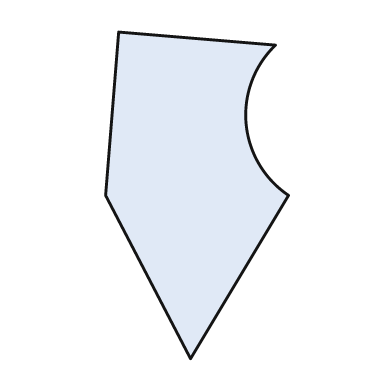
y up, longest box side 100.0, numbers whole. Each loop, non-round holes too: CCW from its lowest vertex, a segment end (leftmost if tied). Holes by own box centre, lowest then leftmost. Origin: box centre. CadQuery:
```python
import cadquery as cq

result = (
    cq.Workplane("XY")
    .moveTo(-2.0, -50.0)
    .lineTo(28.0, 0.0)
    .threePointArc((15.0, 22.0), (24.0, 46.0))
    .lineTo(-24.0, 50.0)
    .lineTo(-28.0, 0.0)
    .close()
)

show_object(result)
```